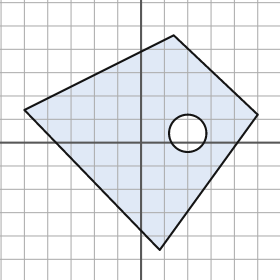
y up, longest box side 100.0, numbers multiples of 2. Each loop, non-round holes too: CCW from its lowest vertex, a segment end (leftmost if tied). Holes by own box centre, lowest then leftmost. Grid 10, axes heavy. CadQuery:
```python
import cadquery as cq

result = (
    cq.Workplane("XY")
    .moveTo(8.0, -46.0)
    .lineTo(50.0, 12.0)
    .lineTo(14.0, 46.0)
    .lineTo(-50.0, 14.0)
    .close()
    .moveTo(20.0, 4.0)
    .circle(8.0)
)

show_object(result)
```